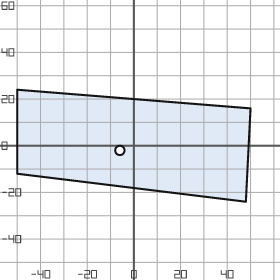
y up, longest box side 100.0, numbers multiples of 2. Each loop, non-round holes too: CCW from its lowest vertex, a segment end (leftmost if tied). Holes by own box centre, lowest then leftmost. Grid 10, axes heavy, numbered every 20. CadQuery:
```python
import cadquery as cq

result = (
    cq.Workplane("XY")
    .moveTo(48.0, -24.0)
    .lineTo(50.0, 16.0)
    .lineTo(-50.0, 24.0)
    .lineTo(-50.0, -12.0)
    .close()
    .moveTo(-6.0, -2.0)
    .circle(2.0)
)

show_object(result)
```